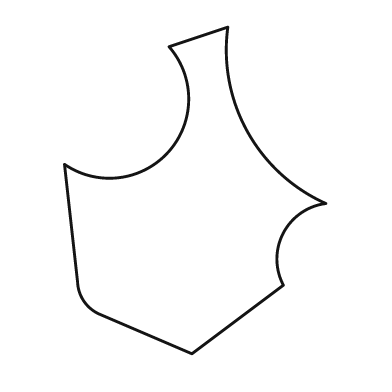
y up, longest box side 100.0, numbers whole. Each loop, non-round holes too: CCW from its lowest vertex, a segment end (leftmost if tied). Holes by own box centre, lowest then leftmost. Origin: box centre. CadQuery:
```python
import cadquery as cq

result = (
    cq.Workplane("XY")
    .moveTo(-1.0, -50.0)
    .lineTo(27.0, -29.0)
    .threePointArc((27.0, -13.0), (40.0, -4.0))
    .threePointArc((16.0, 18.0), (10.0, 50.0))
    .lineTo(-8.0, 44.0)
    .threePointArc((-8.0, 12.0), (-40.0, 8.0))
    .lineTo(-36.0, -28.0)
    .threePointArc((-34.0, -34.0), (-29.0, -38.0))
    .close()
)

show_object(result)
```